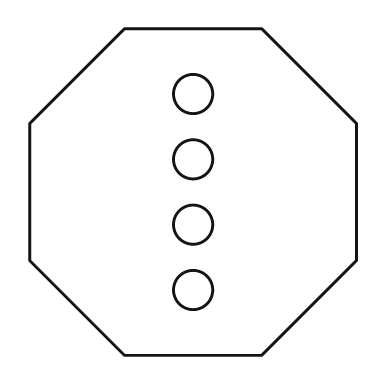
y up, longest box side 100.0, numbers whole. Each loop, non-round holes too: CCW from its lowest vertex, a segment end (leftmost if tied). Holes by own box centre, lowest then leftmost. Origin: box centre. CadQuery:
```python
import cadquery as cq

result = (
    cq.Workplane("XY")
    .moveTo(-21.0, -50.0)
    .lineTo(21.0, -50.0)
    .lineTo(50.0, -21.0)
    .lineTo(50.0, 21.0)
    .lineTo(21.0, 50.0)
    .lineTo(-21.0, 50.0)
    .lineTo(-50.0, 21.0)
    .lineTo(-50.0, -21.0)
    .close()
    .moveTo(0.0, -30.0)
    .circle(6.0)
    .moveTo(0.0, -10.0)
    .circle(6.0)
    .moveTo(0.0, 10.0)
    .circle(6.0)
    .moveTo(0.0, 30.0)
    .circle(6.0)
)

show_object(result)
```